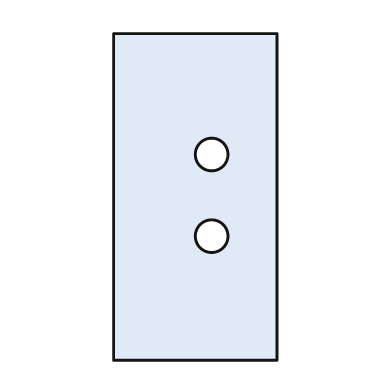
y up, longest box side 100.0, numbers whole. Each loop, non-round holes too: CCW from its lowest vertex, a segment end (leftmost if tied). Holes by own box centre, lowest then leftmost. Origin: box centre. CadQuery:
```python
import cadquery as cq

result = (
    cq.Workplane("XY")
    .moveTo(-25.0, -50.0)
    .lineTo(25.0, -50.0)
    .lineTo(25.0, 50.0)
    .lineTo(-25.0, 50.0)
    .close()
    .moveTo(5.0, -12.0)
    .circle(5.0)
    .moveTo(5.0, 13.0)
    .circle(5.0)
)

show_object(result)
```